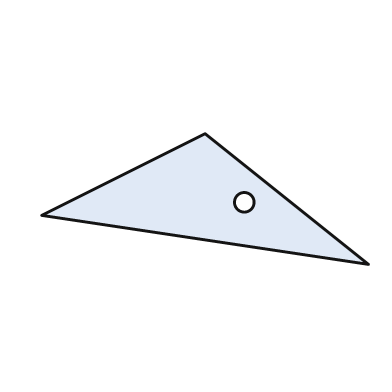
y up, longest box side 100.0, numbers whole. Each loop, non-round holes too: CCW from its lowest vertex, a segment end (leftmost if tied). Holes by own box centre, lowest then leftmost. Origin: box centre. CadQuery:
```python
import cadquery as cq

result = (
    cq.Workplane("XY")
    .moveTo(50.0, -20.0)
    .lineTo(0.0, 20.0)
    .lineTo(-50.0, -5.0)
    .close()
    .moveTo(12.0, -1.0)
    .circle(3.0)
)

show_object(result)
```